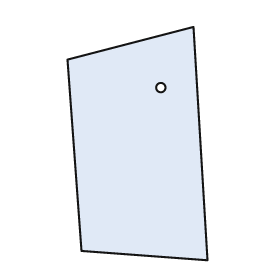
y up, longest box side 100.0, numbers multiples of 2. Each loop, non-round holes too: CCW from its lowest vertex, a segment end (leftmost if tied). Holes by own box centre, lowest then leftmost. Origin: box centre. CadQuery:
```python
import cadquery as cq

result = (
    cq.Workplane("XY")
    .moveTo(30.0, -50.0)
    .lineTo(24.0, 50.0)
    .lineTo(-30.0, 36.0)
    .lineTo(-24.0, -46.0)
    .close()
    .moveTo(10.0, 24.0)
    .circle(2.0)
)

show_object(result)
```